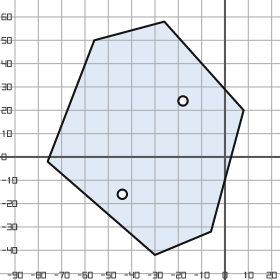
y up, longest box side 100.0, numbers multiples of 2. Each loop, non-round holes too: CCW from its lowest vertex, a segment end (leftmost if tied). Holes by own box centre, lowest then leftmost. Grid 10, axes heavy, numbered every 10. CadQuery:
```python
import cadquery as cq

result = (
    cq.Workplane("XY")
    .moveTo(-30.0, -42.0)
    .lineTo(-6.0, -32.0)
    .lineTo(8.0, 20.0)
    .lineTo(-26.0, 58.0)
    .lineTo(-56.0, 50.0)
    .lineTo(-76.0, -2.0)
    .close()
    .moveTo(-44.0, -16.0)
    .circle(2.0)
    .moveTo(-18.0, 24.0)
    .circle(2.0)
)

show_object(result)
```